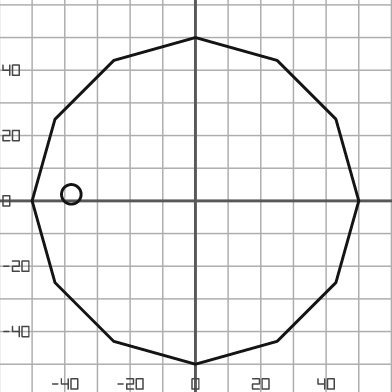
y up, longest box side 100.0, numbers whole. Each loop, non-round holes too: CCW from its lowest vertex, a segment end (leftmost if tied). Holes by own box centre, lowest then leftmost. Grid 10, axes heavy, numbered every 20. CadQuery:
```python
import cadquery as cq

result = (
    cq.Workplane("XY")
    .moveTo(0.0, -50.0)
    .lineTo(25.0, -43.0)
    .lineTo(43.0, -25.0)
    .lineTo(50.0, 0.0)
    .lineTo(43.0, 25.0)
    .lineTo(25.0, 43.0)
    .lineTo(0.0, 50.0)
    .lineTo(-25.0, 43.0)
    .lineTo(-43.0, 25.0)
    .lineTo(-50.0, 0.0)
    .lineTo(-43.0, -25.0)
    .lineTo(-25.0, -43.0)
    .close()
    .moveTo(-38.0, 2.0)
    .circle(3.0)
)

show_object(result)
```